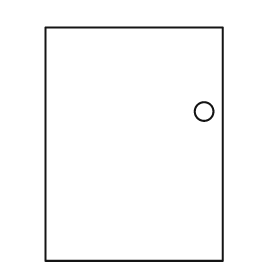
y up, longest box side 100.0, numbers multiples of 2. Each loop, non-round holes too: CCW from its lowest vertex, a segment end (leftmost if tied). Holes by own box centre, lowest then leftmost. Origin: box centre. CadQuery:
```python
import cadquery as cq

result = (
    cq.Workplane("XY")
    .moveTo(-38.0, -50.0)
    .lineTo(38.0, -50.0)
    .lineTo(38.0, 50.0)
    .lineTo(-38.0, 50.0)
    .close()
    .moveTo(30.0, 14.0)
    .circle(4.0)
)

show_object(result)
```